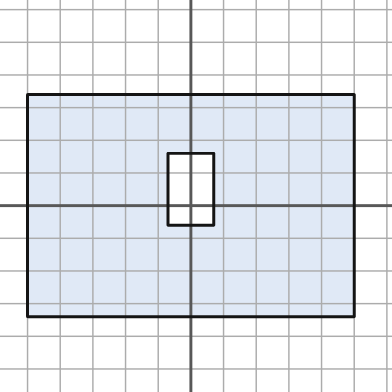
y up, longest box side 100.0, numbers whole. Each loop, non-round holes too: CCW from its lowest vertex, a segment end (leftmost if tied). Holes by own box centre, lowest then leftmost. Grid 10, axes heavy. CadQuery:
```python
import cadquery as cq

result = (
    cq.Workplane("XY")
    .moveTo(-50.0, -34.0)
    .lineTo(50.0, -34.0)
    .lineTo(50.0, 34.0)
    .lineTo(-50.0, 34.0)
    .close()
    .moveTo(-7.0, -6.0)
    .lineTo(7.0, -6.0)
    .lineTo(7.0, 16.0)
    .lineTo(-7.0, 16.0)
    .close()
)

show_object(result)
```